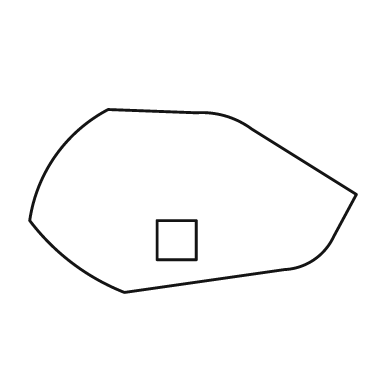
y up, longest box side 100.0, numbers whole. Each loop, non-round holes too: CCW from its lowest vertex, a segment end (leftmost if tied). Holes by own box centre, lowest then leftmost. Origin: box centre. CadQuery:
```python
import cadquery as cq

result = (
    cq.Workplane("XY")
    .moveTo(-21.0, -28.0)
    .lineTo(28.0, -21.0)
    .threePointArc((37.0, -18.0), (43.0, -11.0))
    .lineTo(50.0, 2.0)
    .lineTo(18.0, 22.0)
    .threePointArc((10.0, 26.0), (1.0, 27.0))
    .lineTo(-26.0, 28.0)
    .threePointArc((-42.0, 14.0), (-50.0, -6.0))
    .threePointArc((-37.0, -19.0), (-21.0, -28.0))
    .close()
    .moveTo(-11.0, -18.0)
    .lineTo(1.0, -18.0)
    .lineTo(1.0, -6.0)
    .lineTo(-11.0, -6.0)
    .close()
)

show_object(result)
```